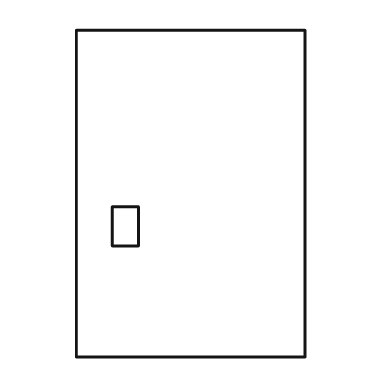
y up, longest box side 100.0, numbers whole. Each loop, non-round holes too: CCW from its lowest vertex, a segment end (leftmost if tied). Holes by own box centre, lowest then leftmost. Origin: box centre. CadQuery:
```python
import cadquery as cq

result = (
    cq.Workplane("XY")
    .moveTo(-35.0, -50.0)
    .lineTo(35.0, -50.0)
    .lineTo(35.0, 50.0)
    .lineTo(-35.0, 50.0)
    .close()
    .moveTo(-24.0, -16.0)
    .lineTo(-16.0, -16.0)
    .lineTo(-16.0, -4.0)
    .lineTo(-24.0, -4.0)
    .close()
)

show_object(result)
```